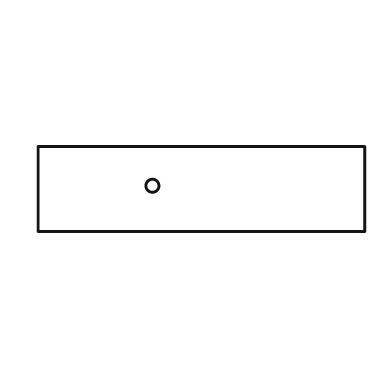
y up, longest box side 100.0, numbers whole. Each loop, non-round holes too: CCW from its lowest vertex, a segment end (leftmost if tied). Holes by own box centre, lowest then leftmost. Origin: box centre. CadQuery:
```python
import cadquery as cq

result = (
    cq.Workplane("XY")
    .moveTo(-50.0, -13.0)
    .lineTo(50.0, -13.0)
    .lineTo(50.0, 13.0)
    .lineTo(-50.0, 13.0)
    .close()
    .moveTo(-15.0, 1.0)
    .circle(2.0)
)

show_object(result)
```